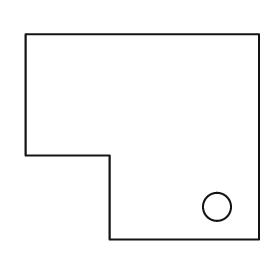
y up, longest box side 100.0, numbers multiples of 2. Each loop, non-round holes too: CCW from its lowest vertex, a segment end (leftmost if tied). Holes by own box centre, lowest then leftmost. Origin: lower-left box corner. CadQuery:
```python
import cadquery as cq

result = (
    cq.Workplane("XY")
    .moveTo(36.0, 0.0)
    .lineTo(100.0, 0.0)
    .lineTo(100.0, 88.0)
    .lineTo(0.0, 88.0)
    .lineTo(0.0, 36.0)
    .lineTo(36.0, 36.0)
    .close()
    .moveTo(82.0, 14.0)
    .circle(6.0)
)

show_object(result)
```